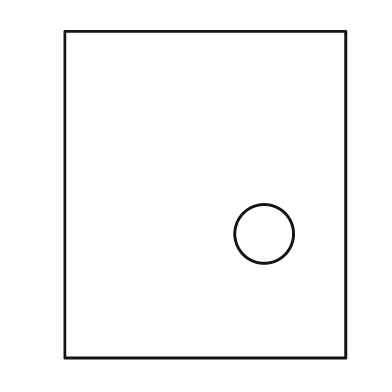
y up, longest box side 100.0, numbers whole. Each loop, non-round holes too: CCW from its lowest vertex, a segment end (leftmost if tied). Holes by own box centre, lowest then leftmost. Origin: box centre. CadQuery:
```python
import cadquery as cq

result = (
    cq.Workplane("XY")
    .moveTo(-43.0, -50.0)
    .lineTo(43.0, -50.0)
    .lineTo(43.0, 50.0)
    .lineTo(-43.0, 50.0)
    .close()
    .moveTo(18.0, -12.0)
    .circle(9.0)
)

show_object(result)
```